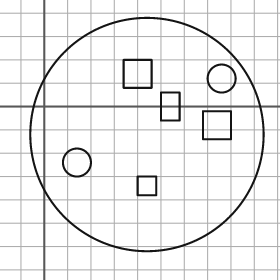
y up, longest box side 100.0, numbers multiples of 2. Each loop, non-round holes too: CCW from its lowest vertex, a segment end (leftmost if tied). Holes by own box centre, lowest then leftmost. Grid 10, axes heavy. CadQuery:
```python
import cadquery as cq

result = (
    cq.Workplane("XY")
    .moveTo(44.0, -12.0)
    .circle(50.0)
    .moveTo(40.0, -38.0)
    .lineTo(48.0, -38.0)
    .lineTo(48.0, -30.0)
    .lineTo(40.0, -30.0)
    .close()
    .moveTo(14.0, -24.0)
    .circle(6.0)
    .moveTo(68.0, -14.0)
    .lineTo(80.0, -14.0)
    .lineTo(80.0, -2.0)
    .lineTo(68.0, -2.0)
    .close()
    .moveTo(50.0, -6.0)
    .lineTo(58.0, -6.0)
    .lineTo(58.0, 6.0)
    .lineTo(50.0, 6.0)
    .close()
    .moveTo(76.0, 12.0)
    .circle(6.0)
    .moveTo(34.0, 8.0)
    .lineTo(46.0, 8.0)
    .lineTo(46.0, 20.0)
    .lineTo(34.0, 20.0)
    .close()
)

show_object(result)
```